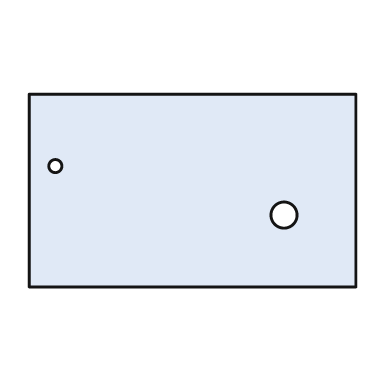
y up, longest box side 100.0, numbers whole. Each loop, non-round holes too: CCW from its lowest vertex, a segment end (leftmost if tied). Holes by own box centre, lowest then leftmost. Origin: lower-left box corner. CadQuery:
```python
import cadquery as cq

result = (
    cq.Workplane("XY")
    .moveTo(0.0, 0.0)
    .lineTo(100.0, 0.0)
    .lineTo(100.0, 59.0)
    .lineTo(0.0, 59.0)
    .close()
    .moveTo(78.0, 22.0)
    .circle(4.0)
    .moveTo(8.0, 37.0)
    .circle(2.0)
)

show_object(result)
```